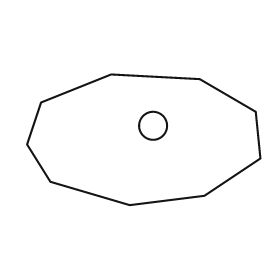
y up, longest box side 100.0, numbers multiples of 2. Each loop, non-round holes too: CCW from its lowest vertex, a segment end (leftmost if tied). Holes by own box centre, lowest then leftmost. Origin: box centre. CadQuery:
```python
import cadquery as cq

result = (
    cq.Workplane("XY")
    .moveTo(-6.0, -28.0)
    .lineTo(26.0, -24.0)
    .lineTo(50.0, -8.0)
    .lineTo(48.0, 12.0)
    .lineTo(24.0, 26.0)
    .lineTo(-14.0, 28.0)
    .lineTo(-44.0, 16.0)
    .lineTo(-50.0, -2.0)
    .lineTo(-40.0, -18.0)
    .close()
    .moveTo(4.0, 6.0)
    .circle(6.0)
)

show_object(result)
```